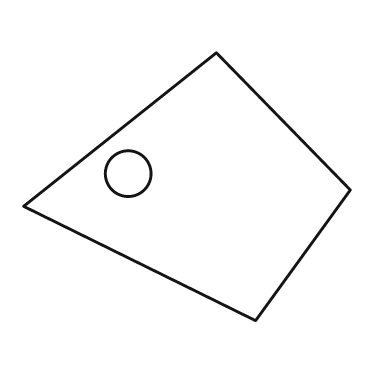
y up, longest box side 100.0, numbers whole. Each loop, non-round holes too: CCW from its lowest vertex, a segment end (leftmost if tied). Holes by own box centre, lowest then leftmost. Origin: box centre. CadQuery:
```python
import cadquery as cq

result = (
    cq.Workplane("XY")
    .moveTo(21.0, -41.0)
    .lineTo(50.0, -1.0)
    .lineTo(9.0, 41.0)
    .lineTo(-50.0, -6.0)
    .close()
    .moveTo(-18.0, 4.0)
    .circle(7.0)
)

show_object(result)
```